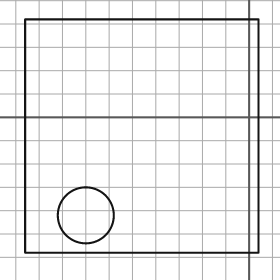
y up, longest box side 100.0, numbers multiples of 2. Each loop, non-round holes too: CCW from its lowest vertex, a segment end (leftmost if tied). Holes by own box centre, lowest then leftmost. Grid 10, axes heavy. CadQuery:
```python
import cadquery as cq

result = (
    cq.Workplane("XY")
    .moveTo(-96.0, -58.0)
    .lineTo(4.0, -58.0)
    .lineTo(4.0, 42.0)
    .lineTo(-96.0, 42.0)
    .close()
    .moveTo(-70.0, -42.0)
    .circle(12.0)
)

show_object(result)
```